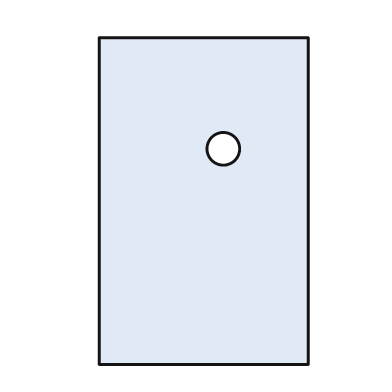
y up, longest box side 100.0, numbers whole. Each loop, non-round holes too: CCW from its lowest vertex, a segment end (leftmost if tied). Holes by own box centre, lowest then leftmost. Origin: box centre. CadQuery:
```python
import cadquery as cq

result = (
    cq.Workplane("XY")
    .moveTo(-32.0, -50.0)
    .lineTo(32.0, -50.0)
    .lineTo(32.0, 50.0)
    .lineTo(-32.0, 50.0)
    .close()
    .moveTo(6.0, 16.0)
    .circle(5.0)
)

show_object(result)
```